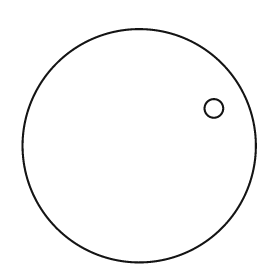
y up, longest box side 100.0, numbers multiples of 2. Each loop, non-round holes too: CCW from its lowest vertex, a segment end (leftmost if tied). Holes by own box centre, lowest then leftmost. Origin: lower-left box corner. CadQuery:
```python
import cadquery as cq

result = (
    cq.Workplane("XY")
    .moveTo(50.0, 50.0)
    .circle(50.0)
    .moveTo(82.0, 66.0)
    .circle(4.0)
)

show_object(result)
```